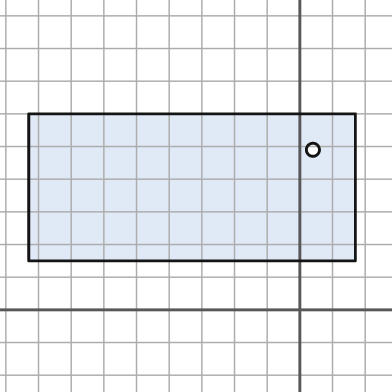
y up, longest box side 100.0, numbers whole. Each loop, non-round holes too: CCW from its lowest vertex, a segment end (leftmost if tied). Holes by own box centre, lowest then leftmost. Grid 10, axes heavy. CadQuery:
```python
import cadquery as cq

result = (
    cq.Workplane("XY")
    .moveTo(-83.0, 15.0)
    .lineTo(17.0, 15.0)
    .lineTo(17.0, 60.0)
    .lineTo(-83.0, 60.0)
    .close()
    .moveTo(4.0, 49.0)
    .circle(2.0)
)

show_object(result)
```